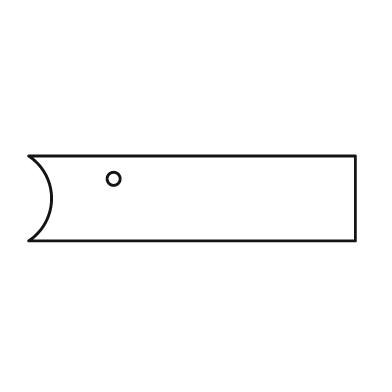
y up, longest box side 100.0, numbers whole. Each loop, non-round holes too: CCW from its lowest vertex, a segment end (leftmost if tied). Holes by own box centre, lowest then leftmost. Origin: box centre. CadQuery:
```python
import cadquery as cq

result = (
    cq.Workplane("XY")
    .moveTo(-50.0, -13.0)
    .lineTo(50.0, -13.0)
    .lineTo(50.0, 13.0)
    .lineTo(-50.0, 13.0)
    .threePointArc((-43.0, 0.0), (-50.0, -13.0))
    .close()
    .moveTo(-24.0, 6.0)
    .circle(2.0)
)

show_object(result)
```